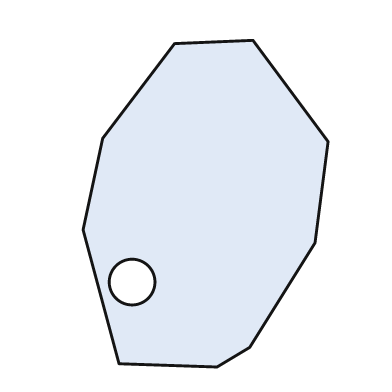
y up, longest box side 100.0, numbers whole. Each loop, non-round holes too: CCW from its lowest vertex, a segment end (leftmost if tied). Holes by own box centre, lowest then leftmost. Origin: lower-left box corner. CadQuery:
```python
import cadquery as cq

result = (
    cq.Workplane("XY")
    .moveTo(41.0, 0.0)
    .lineTo(51.0, 6.0)
    .lineTo(71.0, 38.0)
    .lineTo(75.0, 69.0)
    .lineTo(52.0, 100.0)
    .lineTo(28.0, 99.0)
    .lineTo(6.0, 70.0)
    .lineTo(0.0, 42.0)
    .lineTo(11.0, 1.0)
    .close()
    .moveTo(15.0, 26.0)
    .circle(7.0)
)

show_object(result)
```